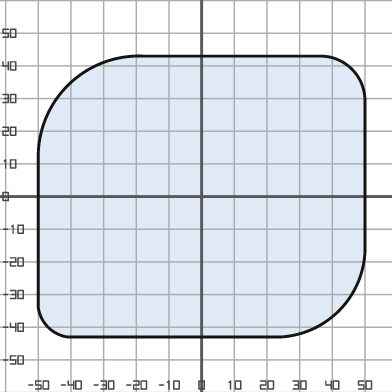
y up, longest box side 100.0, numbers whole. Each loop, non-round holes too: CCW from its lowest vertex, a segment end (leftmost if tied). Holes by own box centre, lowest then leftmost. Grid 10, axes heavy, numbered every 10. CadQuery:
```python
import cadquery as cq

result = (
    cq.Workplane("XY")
    .moveTo(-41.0, -43.0)
    .lineTo(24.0, -43.0)
    .threePointArc((42.0, -35.0), (50.0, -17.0))
    .lineTo(50.0, 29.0)
    .threePointArc((46.0, 39.0), (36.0, 43.0))
    .lineTo(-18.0, 43.0)
    .threePointArc((-41.0, 34.0), (-50.0, 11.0))
    .lineTo(-50.0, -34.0)
    .threePointArc((-47.0, -40.0), (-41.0, -43.0))
    .close()
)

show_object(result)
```